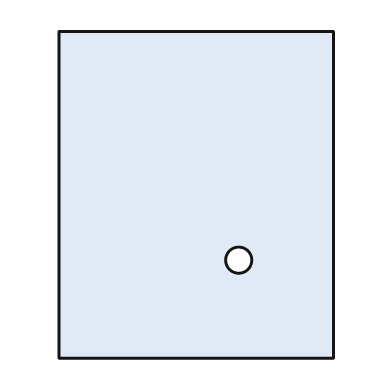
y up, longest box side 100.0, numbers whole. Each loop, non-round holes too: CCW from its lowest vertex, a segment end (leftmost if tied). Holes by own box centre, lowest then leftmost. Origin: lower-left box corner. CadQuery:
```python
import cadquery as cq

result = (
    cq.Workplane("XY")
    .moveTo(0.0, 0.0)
    .lineTo(84.0, 0.0)
    .lineTo(84.0, 100.0)
    .lineTo(0.0, 100.0)
    .close()
    .moveTo(55.0, 30.0)
    .circle(4.0)
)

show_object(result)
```